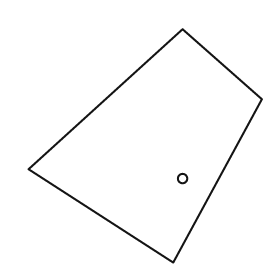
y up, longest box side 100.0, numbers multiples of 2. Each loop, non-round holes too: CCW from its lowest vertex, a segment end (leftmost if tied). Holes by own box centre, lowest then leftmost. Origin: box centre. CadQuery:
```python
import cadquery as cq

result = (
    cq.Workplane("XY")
    .moveTo(12.0, -50.0)
    .lineTo(50.0, 20.0)
    .lineTo(16.0, 50.0)
    .lineTo(-50.0, -10.0)
    .close()
    .moveTo(16.0, -14.0)
    .circle(2.0)
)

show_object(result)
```